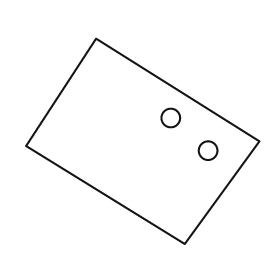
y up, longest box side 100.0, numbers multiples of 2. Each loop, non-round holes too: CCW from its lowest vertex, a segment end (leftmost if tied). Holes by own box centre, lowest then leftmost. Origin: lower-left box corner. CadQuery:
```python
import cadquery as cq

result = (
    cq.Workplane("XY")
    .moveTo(68.0, 0.0)
    .lineTo(100.0, 44.0)
    .lineTo(30.0, 88.0)
    .lineTo(0.0, 42.0)
    .close()
    .moveTo(78.0, 40.0)
    .circle(4.0)
    .moveTo(62.0, 54.0)
    .circle(4.0)
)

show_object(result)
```